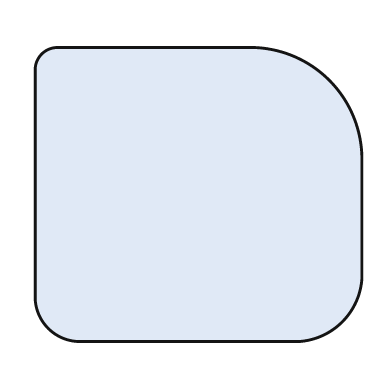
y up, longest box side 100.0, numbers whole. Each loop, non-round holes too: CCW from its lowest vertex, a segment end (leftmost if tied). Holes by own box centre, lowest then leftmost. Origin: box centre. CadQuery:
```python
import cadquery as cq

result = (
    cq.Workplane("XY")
    .moveTo(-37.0, -45.0)
    .lineTo(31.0, -45.0)
    .threePointArc((44.0, -39.0), (50.0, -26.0))
    .lineTo(50.0, 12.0)
    .threePointArc((40.0, 35.0), (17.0, 45.0))
    .lineTo(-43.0, 45.0)
    .threePointArc((-48.0, 43.0), (-50.0, 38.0))
    .lineTo(-50.0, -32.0)
    .threePointArc((-46.0, -41.0), (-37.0, -45.0))
    .close()
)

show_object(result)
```